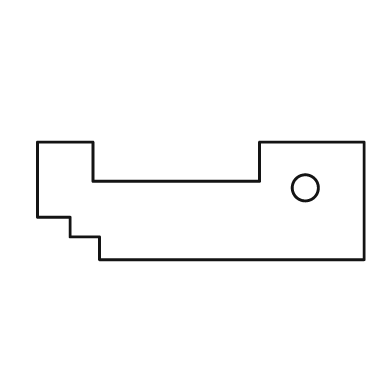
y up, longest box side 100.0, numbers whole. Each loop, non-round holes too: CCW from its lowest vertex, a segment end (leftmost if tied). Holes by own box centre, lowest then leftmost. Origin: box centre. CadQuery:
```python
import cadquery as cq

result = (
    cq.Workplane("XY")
    .moveTo(-31.0, -18.0)
    .lineTo(50.0, -18.0)
    .lineTo(50.0, 18.0)
    .lineTo(18.0, 18.0)
    .lineTo(18.0, 6.0)
    .lineTo(-33.0, 6.0)
    .lineTo(-33.0, 18.0)
    .lineTo(-50.0, 18.0)
    .lineTo(-50.0, -5.0)
    .lineTo(-40.0, -5.0)
    .lineTo(-40.0, -11.0)
    .lineTo(-31.0, -11.0)
    .close()
    .moveTo(32.0, 4.0)
    .circle(4.0)
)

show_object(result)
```